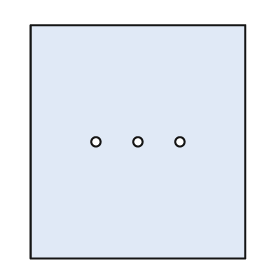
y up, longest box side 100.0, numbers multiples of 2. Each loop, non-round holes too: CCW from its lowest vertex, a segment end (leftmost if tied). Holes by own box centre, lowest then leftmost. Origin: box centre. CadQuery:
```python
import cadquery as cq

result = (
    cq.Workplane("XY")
    .moveTo(-46.0, -50.0)
    .lineTo(46.0, -50.0)
    .lineTo(46.0, 50.0)
    .lineTo(-46.0, 50.0)
    .close()
    .moveTo(-18.0, 0.0)
    .circle(2.0)
    .moveTo(0.0, 0.0)
    .circle(2.0)
    .moveTo(18.0, 0.0)
    .circle(2.0)
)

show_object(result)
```